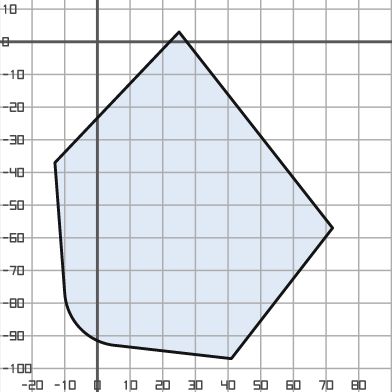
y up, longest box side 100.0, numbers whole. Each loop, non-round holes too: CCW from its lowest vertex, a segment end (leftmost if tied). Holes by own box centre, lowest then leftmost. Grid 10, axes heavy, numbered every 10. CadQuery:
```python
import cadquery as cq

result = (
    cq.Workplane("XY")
    .moveTo(41.0, -97.0)
    .lineTo(72.0, -57.0)
    .lineTo(25.0, 3.0)
    .lineTo(-13.0, -37.0)
    .lineTo(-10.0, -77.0)
    .threePointArc((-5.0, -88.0), (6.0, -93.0))
    .close()
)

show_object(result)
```